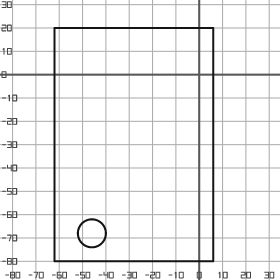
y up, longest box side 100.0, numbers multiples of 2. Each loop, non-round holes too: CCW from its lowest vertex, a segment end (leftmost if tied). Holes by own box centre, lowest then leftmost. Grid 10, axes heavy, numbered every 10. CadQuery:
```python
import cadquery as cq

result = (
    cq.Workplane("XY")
    .moveTo(-62.0, -80.0)
    .lineTo(6.0, -80.0)
    .lineTo(6.0, 20.0)
    .lineTo(-62.0, 20.0)
    .close()
    .moveTo(-46.0, -68.0)
    .circle(6.0)
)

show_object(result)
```